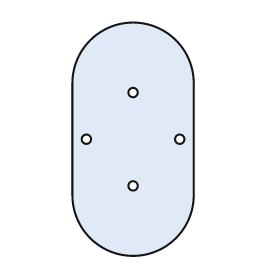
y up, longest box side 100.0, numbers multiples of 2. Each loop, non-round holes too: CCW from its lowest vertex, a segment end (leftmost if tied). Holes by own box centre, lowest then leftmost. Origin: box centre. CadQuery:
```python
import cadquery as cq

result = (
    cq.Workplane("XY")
    .moveTo(-26.0, -24.0)
    .threePointArc((0.0, -50.0), (26.0, -24.0))
    .lineTo(26.0, 24.0)
    .threePointArc((0.0, 50.0), (-26.0, 24.0))
    .close()
    .moveTo(0.0, -20.0)
    .circle(2.0)
    .moveTo(-20.0, 0.0)
    .circle(2.0)
    .moveTo(20.0, 0.0)
    .circle(2.0)
    .moveTo(0.0, 20.0)
    .circle(2.0)
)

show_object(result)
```